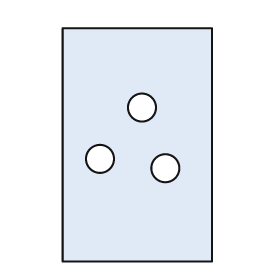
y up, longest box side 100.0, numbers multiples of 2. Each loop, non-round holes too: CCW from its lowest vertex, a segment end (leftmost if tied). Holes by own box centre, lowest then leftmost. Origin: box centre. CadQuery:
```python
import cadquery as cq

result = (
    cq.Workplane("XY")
    .moveTo(-32.0, -50.0)
    .lineTo(32.0, -50.0)
    .lineTo(32.0, 50.0)
    .lineTo(-32.0, 50.0)
    .close()
    .moveTo(12.0, -10.0)
    .circle(6.0)
    .moveTo(-16.0, -6.0)
    .circle(6.0)
    .moveTo(2.0, 16.0)
    .circle(6.0)
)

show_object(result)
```